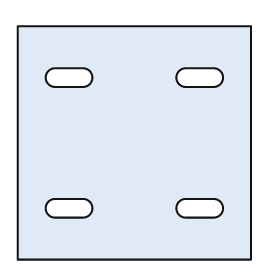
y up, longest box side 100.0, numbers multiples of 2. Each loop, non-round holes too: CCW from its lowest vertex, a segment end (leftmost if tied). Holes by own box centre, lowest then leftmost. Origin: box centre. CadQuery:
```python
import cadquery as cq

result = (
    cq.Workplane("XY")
    .moveTo(-50.0, -50.0)
    .lineTo(50.0, -50.0)
    .lineTo(50.0, 50.0)
    .lineTo(-50.0, 50.0)
    .close()
    .moveTo(-34.0, -32.0)
    .lineTo(-22.0, -32.0)
    .threePointArc((-18.0, -28.0), (-22.0, -24.0))
    .lineTo(-34.0, -24.0)
    .threePointArc((-38.0, -28.0), (-34.0, -32.0))
    .close()
    .moveTo(22.0, -32.0)
    .lineTo(34.0, -32.0)
    .threePointArc((38.0, -28.0), (34.0, -24.0))
    .lineTo(22.0, -24.0)
    .threePointArc((18.0, -28.0), (22.0, -32.0))
    .close()
    .moveTo(-34.0, 24.0)
    .lineTo(-22.0, 24.0)
    .threePointArc((-18.0, 28.0), (-22.0, 32.0))
    .lineTo(-34.0, 32.0)
    .threePointArc((-38.0, 28.0), (-34.0, 24.0))
    .close()
    .moveTo(22.0, 24.0)
    .lineTo(34.0, 24.0)
    .threePointArc((38.0, 28.0), (34.0, 32.0))
    .lineTo(22.0, 32.0)
    .threePointArc((18.0, 28.0), (22.0, 24.0))
    .close()
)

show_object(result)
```